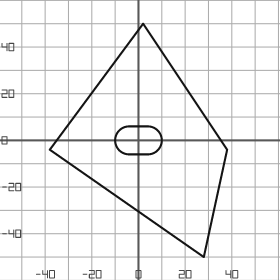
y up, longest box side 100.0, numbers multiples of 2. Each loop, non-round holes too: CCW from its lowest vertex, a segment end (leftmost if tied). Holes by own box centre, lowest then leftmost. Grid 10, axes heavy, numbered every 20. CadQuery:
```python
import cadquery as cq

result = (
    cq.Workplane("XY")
    .moveTo(28.0, -50.0)
    .lineTo(38.0, -4.0)
    .lineTo(2.0, 50.0)
    .lineTo(-38.0, -4.0)
    .close()
    .moveTo(-4.0, -6.0)
    .lineTo(4.0, -6.0)
    .threePointArc((10.0, 0.0), (4.0, 6.0))
    .lineTo(-4.0, 6.0)
    .threePointArc((-10.0, 0.0), (-4.0, -6.0))
    .close()
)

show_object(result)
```